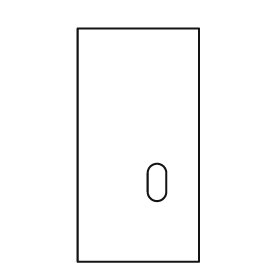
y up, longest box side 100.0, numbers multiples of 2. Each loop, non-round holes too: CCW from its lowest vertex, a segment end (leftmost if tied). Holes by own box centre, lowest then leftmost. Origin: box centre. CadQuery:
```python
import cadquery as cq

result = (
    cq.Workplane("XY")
    .moveTo(-26.0, -50.0)
    .lineTo(26.0, -50.0)
    .lineTo(26.0, 50.0)
    .lineTo(-26.0, 50.0)
    .close()
    .moveTo(4.0, -20.0)
    .threePointArc((8.0, -24.0), (12.0, -20.0))
    .lineTo(12.0, -12.0)
    .threePointArc((8.0, -8.0), (4.0, -12.0))
    .close()
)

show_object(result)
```